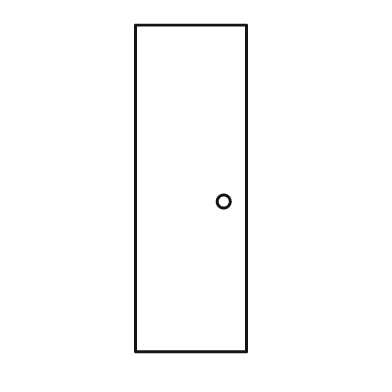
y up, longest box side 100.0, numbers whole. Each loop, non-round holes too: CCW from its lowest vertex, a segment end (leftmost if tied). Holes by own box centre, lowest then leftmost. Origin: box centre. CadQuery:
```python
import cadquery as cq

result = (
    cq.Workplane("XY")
    .moveTo(-17.0, -50.0)
    .lineTo(17.0, -50.0)
    .lineTo(17.0, 50.0)
    .lineTo(-17.0, 50.0)
    .close()
    .moveTo(10.0, -4.0)
    .circle(2.0)
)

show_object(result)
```